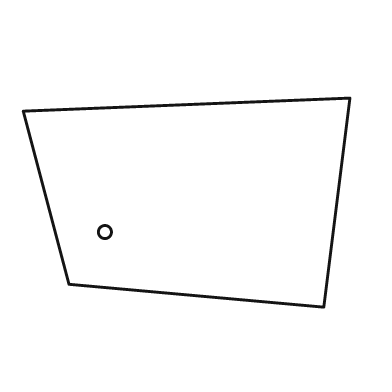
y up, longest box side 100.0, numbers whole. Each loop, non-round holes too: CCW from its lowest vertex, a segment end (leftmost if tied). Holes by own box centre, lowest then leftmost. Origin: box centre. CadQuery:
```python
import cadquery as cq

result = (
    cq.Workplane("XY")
    .moveTo(42.0, -32.0)
    .lineTo(50.0, 32.0)
    .lineTo(-50.0, 28.0)
    .lineTo(-36.0, -25.0)
    .close()
    .moveTo(-25.0, -9.0)
    .circle(2.0)
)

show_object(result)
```